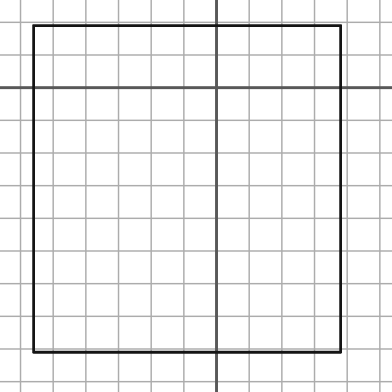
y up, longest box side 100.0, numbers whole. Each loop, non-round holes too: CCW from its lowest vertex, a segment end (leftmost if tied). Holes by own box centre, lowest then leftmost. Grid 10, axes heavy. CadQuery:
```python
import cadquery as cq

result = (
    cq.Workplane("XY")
    .moveTo(-56.0, -81.0)
    .lineTo(38.0, -81.0)
    .lineTo(38.0, 19.0)
    .lineTo(-56.0, 19.0)
    .close()
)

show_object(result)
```